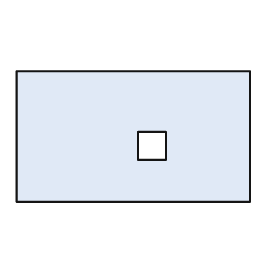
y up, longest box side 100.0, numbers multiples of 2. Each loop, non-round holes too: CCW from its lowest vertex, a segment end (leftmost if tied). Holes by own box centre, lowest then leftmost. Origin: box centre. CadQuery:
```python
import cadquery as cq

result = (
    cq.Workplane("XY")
    .moveTo(-50.0, -28.0)
    .lineTo(50.0, -28.0)
    .lineTo(50.0, 28.0)
    .lineTo(-50.0, 28.0)
    .close()
    .moveTo(2.0, -10.0)
    .lineTo(14.0, -10.0)
    .lineTo(14.0, 2.0)
    .lineTo(2.0, 2.0)
    .close()
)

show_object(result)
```